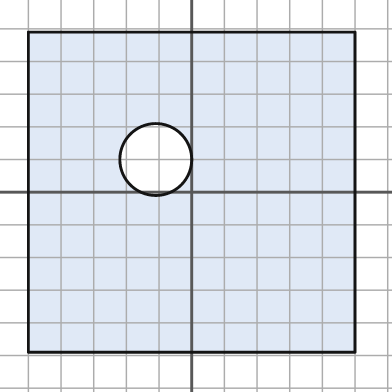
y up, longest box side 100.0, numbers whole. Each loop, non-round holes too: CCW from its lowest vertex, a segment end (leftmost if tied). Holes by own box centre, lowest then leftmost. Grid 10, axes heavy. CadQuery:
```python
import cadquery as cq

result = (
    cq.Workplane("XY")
    .moveTo(-50.0, -49.0)
    .lineTo(50.0, -49.0)
    .lineTo(50.0, 49.0)
    .lineTo(-50.0, 49.0)
    .close()
    .moveTo(-11.0, 10.0)
    .circle(11.0)
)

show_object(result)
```